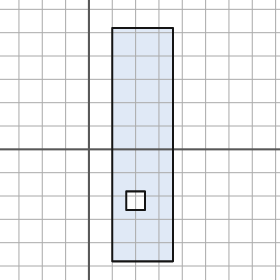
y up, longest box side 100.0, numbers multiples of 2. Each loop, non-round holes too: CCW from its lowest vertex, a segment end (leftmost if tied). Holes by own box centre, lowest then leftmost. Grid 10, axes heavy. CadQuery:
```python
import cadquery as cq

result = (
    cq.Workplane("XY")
    .moveTo(10.0, -48.0)
    .lineTo(36.0, -48.0)
    .lineTo(36.0, 52.0)
    .lineTo(10.0, 52.0)
    .close()
    .moveTo(16.0, -26.0)
    .lineTo(24.0, -26.0)
    .lineTo(24.0, -18.0)
    .lineTo(16.0, -18.0)
    .close()
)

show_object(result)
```